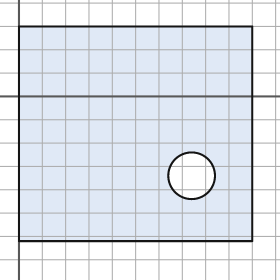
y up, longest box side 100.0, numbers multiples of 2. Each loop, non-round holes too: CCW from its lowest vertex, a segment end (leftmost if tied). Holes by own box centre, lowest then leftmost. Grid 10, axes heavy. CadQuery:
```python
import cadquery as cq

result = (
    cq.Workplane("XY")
    .moveTo(0.0, -62.0)
    .lineTo(100.0, -62.0)
    .lineTo(100.0, 30.0)
    .lineTo(0.0, 30.0)
    .close()
    .moveTo(74.0, -34.0)
    .circle(10.0)
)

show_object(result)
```